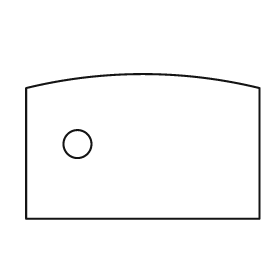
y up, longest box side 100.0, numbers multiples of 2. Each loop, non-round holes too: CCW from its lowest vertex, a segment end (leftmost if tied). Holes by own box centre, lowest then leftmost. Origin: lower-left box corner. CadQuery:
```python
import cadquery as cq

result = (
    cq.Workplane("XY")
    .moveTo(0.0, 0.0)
    .lineTo(100.0, 0.0)
    .lineTo(100.0, 56.0)
    .threePointArc((50.0, 62.0), (0.0, 56.0))
    .close()
    .moveTo(22.0, 32.0)
    .circle(6.0)
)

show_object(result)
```